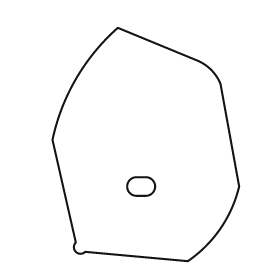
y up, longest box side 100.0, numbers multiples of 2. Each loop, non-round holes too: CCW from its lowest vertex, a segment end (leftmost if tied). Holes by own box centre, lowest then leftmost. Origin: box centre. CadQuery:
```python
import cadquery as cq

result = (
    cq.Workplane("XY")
    .moveTo(18.0, -50.0)
    .threePointArc((32.0, -36.0), (40.0, -18.0))
    .lineTo(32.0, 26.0)
    .threePointArc((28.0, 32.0), (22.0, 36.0))
    .lineTo(-12.0, 50.0)
    .threePointArc((-30.0, 28.0), (-40.0, 2.0))
    .lineTo(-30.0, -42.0)
    .threePointArc((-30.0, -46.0), (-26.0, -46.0))
    .close()
    .moveTo(-4.0, -22.0)
    .lineTo(0.0, -22.0)
    .threePointArc((4.0, -18.0), (0.0, -14.0))
    .lineTo(-4.0, -14.0)
    .threePointArc((-8.0, -18.0), (-4.0, -22.0))
    .close()
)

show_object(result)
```